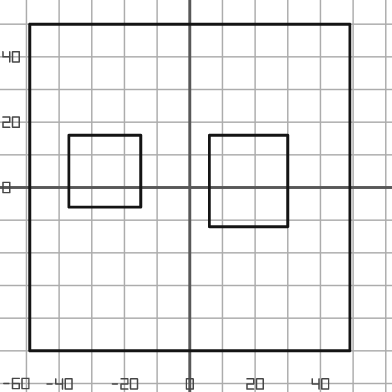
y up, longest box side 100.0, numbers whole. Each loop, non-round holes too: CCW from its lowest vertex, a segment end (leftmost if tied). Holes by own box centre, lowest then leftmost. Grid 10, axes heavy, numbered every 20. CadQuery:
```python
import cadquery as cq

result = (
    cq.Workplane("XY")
    .moveTo(-49.0, -50.0)
    .lineTo(49.0, -50.0)
    .lineTo(49.0, 50.0)
    .lineTo(-49.0, 50.0)
    .close()
    .moveTo(6.0, -12.0)
    .lineTo(30.0, -12.0)
    .lineTo(30.0, 16.0)
    .lineTo(6.0, 16.0)
    .close()
    .moveTo(-37.0, -6.0)
    .lineTo(-15.0, -6.0)
    .lineTo(-15.0, 16.0)
    .lineTo(-37.0, 16.0)
    .close()
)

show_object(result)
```